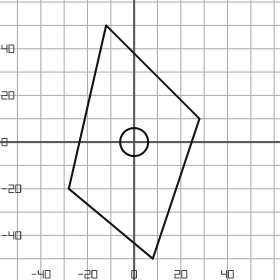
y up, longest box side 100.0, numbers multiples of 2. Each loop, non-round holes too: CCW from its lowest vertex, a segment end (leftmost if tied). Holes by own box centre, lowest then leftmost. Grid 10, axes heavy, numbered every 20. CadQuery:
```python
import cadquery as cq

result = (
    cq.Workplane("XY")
    .moveTo(8.0, -50.0)
    .lineTo(28.0, 10.0)
    .lineTo(-12.0, 50.0)
    .lineTo(-28.0, -20.0)
    .close()
    .moveTo(0.0, 0.0)
    .circle(6.0)
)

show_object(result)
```